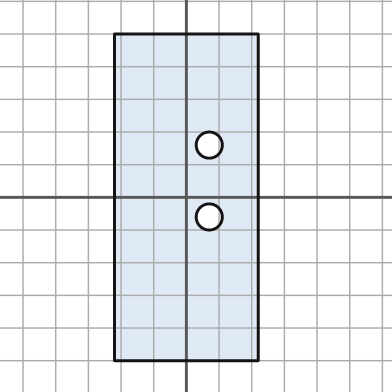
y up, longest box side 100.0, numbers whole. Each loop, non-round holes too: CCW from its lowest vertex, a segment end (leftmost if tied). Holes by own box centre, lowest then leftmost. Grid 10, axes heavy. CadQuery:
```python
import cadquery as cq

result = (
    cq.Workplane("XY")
    .moveTo(-22.0, -50.0)
    .lineTo(22.0, -50.0)
    .lineTo(22.0, 50.0)
    .lineTo(-22.0, 50.0)
    .close()
    .moveTo(7.0, -6.0)
    .circle(4.0)
    .moveTo(7.0, 16.0)
    .circle(4.0)
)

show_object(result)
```